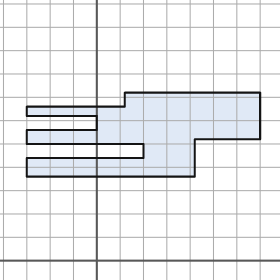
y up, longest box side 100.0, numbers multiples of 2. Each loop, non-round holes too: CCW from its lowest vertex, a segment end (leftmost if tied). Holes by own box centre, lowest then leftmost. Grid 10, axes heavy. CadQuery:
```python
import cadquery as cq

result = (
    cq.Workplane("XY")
    .moveTo(-30.0, 36.0)
    .lineTo(42.0, 36.0)
    .lineTo(42.0, 52.0)
    .lineTo(70.0, 52.0)
    .lineTo(70.0, 72.0)
    .lineTo(12.0, 72.0)
    .lineTo(12.0, 66.0)
    .lineTo(-30.0, 66.0)
    .lineTo(-30.0, 62.0)
    .lineTo(0.0, 62.0)
    .lineTo(0.0, 56.0)
    .lineTo(-30.0, 56.0)
    .lineTo(-30.0, 50.0)
    .lineTo(20.0, 50.0)
    .lineTo(20.0, 44.0)
    .lineTo(-30.0, 44.0)
    .close()
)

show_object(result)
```